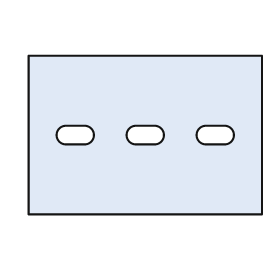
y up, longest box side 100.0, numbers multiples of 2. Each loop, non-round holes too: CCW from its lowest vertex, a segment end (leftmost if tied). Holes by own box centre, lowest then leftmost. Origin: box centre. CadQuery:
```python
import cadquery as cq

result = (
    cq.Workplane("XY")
    .moveTo(-50.0, -34.0)
    .lineTo(50.0, -34.0)
    .lineTo(50.0, 34.0)
    .lineTo(-50.0, 34.0)
    .close()
    .moveTo(-34.0, -4.0)
    .lineTo(-26.0, -4.0)
    .threePointArc((-22.0, 0.0), (-26.0, 4.0))
    .lineTo(-34.0, 4.0)
    .threePointArc((-38.0, 0.0), (-34.0, -4.0))
    .close()
    .moveTo(-4.0, -4.0)
    .lineTo(4.0, -4.0)
    .threePointArc((8.0, 0.0), (4.0, 4.0))
    .lineTo(-4.0, 4.0)
    .threePointArc((-8.0, 0.0), (-4.0, -4.0))
    .close()
    .moveTo(26.0, -4.0)
    .lineTo(34.0, -4.0)
    .threePointArc((38.0, 0.0), (34.0, 4.0))
    .lineTo(26.0, 4.0)
    .threePointArc((22.0, 0.0), (26.0, -4.0))
    .close()
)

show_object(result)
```